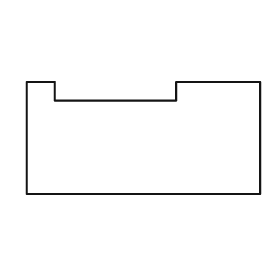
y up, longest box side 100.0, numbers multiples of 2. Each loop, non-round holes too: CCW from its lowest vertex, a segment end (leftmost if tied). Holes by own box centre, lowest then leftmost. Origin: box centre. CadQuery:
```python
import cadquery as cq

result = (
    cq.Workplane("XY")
    .moveTo(-50.0, -24.0)
    .lineTo(50.0, -24.0)
    .lineTo(50.0, 24.0)
    .lineTo(14.0, 24.0)
    .lineTo(14.0, 16.0)
    .lineTo(-38.0, 16.0)
    .lineTo(-38.0, 24.0)
    .lineTo(-50.0, 24.0)
    .close()
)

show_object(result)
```